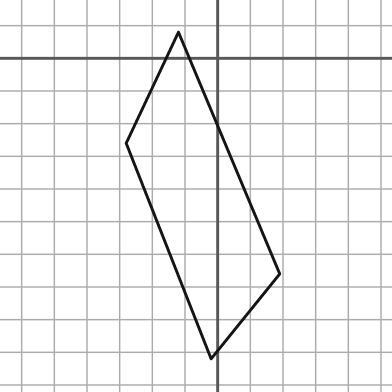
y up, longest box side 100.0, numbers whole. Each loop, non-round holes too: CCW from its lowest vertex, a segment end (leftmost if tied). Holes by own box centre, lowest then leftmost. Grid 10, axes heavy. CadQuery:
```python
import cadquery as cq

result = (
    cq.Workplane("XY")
    .moveTo(-2.0, -92.0)
    .lineTo(19.0, -66.0)
    .lineTo(-12.0, 8.0)
    .lineTo(-28.0, -26.0)
    .close()
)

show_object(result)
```